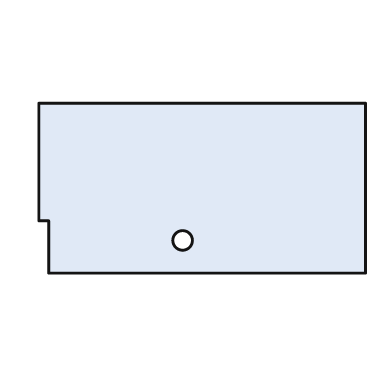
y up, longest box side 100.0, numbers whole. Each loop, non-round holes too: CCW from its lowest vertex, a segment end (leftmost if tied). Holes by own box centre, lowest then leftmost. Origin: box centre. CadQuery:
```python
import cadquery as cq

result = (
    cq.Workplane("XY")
    .moveTo(-47.0, -26.0)
    .lineTo(50.0, -26.0)
    .lineTo(50.0, 26.0)
    .lineTo(-50.0, 26.0)
    .lineTo(-50.0, -10.0)
    .lineTo(-47.0, -10.0)
    .close()
    .moveTo(-6.0, -16.0)
    .circle(3.0)
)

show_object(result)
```